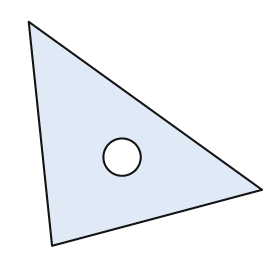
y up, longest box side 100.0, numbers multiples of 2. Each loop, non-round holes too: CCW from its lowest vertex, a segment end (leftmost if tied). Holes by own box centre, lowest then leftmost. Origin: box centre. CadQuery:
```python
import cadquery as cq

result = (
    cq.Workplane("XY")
    .moveTo(-40.0, -48.0)
    .lineTo(50.0, -24.0)
    .lineTo(-50.0, 48.0)
    .close()
    .moveTo(-10.0, -10.0)
    .circle(8.0)
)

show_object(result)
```